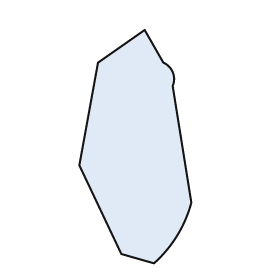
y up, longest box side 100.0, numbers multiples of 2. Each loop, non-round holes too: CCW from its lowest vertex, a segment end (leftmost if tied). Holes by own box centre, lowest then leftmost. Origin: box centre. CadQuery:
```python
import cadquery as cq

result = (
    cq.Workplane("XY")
    .moveTo(8.0, -50.0)
    .threePointArc((18.0, -38.0), (24.0, -24.0))
    .lineTo(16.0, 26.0)
    .threePointArc((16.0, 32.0), (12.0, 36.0))
    .lineTo(4.0, 50.0)
    .lineTo(-16.0, 36.0)
    .lineTo(-24.0, -8.0)
    .lineTo(-6.0, -46.0)
    .close()
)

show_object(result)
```